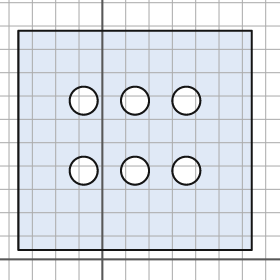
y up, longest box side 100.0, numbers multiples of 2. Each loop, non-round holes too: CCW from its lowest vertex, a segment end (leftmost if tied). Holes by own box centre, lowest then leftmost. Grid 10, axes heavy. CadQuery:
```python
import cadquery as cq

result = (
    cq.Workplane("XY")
    .moveTo(-36.0, 4.0)
    .lineTo(64.0, 4.0)
    .lineTo(64.0, 98.0)
    .lineTo(-36.0, 98.0)
    .close()
    .moveTo(-8.0, 38.0)
    .circle(6.0)
    .moveTo(14.0, 38.0)
    .circle(6.0)
    .moveTo(36.0, 38.0)
    .circle(6.0)
    .moveTo(-8.0, 68.0)
    .circle(6.0)
    .moveTo(14.0, 68.0)
    .circle(6.0)
    .moveTo(36.0, 68.0)
    .circle(6.0)
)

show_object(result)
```